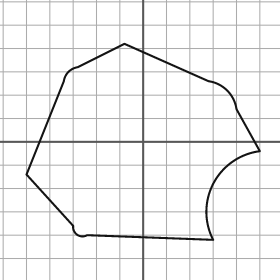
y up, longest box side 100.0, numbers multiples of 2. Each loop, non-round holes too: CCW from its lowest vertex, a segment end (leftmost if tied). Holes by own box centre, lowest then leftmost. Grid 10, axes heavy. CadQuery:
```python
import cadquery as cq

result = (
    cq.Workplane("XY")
    .moveTo(30.0, -42.0)
    .threePointArc((30.0, -18.0), (50.0, -4.0))
    .lineTo(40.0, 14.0)
    .threePointArc((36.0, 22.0), (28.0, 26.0))
    .lineTo(-8.0, 42.0)
    .lineTo(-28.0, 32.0)
    .threePointArc((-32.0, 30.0), (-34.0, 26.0))
    .lineTo(-50.0, -14.0)
    .lineTo(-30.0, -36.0)
    .threePointArc((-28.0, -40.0), (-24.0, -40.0))
    .close()
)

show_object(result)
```